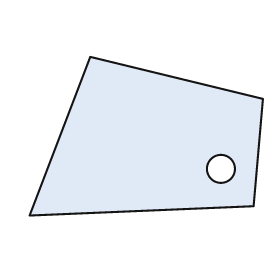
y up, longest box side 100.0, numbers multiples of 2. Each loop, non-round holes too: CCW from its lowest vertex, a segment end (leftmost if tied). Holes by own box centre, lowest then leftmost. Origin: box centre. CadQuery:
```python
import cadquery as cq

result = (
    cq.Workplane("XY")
    .moveTo(-50.0, -34.0)
    .lineTo(46.0, -30.0)
    .lineTo(50.0, 16.0)
    .lineTo(-24.0, 34.0)
    .close()
    .moveTo(32.0, -14.0)
    .circle(6.0)
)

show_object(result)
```